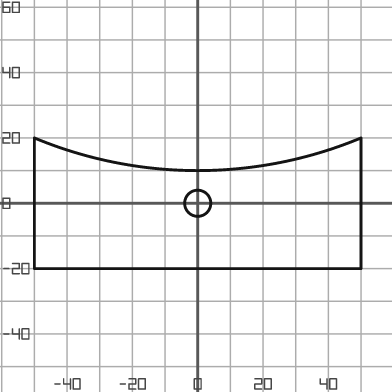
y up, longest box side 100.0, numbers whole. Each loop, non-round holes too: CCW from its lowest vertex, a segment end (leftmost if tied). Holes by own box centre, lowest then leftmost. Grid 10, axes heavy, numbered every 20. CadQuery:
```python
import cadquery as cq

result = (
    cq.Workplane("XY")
    .moveTo(-50.0, -20.0)
    .lineTo(50.0, -20.0)
    .lineTo(50.0, 20.0)
    .threePointArc((0.0, 10.0), (-50.0, 20.0))
    .close()
    .moveTo(0.0, 0.0)
    .circle(4.0)
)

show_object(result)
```